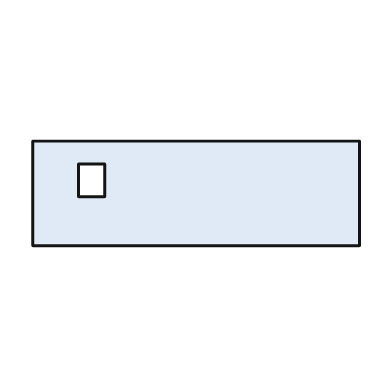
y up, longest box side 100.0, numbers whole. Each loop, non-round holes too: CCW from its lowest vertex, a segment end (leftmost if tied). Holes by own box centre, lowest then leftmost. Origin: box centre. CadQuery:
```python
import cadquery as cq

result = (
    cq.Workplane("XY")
    .moveTo(-50.0, -16.0)
    .lineTo(50.0, -16.0)
    .lineTo(50.0, 16.0)
    .lineTo(-50.0, 16.0)
    .close()
    .moveTo(-36.0, -1.0)
    .lineTo(-28.0, -1.0)
    .lineTo(-28.0, 9.0)
    .lineTo(-36.0, 9.0)
    .close()
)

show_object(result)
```